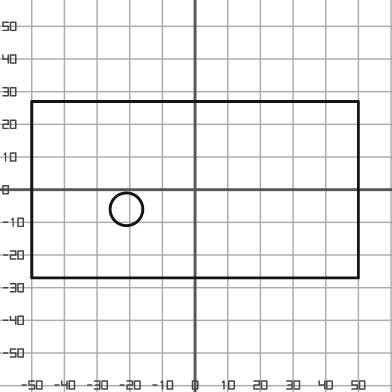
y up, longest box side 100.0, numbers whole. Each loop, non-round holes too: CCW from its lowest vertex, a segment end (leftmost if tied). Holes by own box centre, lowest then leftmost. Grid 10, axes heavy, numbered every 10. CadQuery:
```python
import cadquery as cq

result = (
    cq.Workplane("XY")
    .moveTo(-50.0, -27.0)
    .lineTo(50.0, -27.0)
    .lineTo(50.0, 27.0)
    .lineTo(-50.0, 27.0)
    .close()
    .moveTo(-21.0, -6.0)
    .circle(5.0)
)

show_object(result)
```